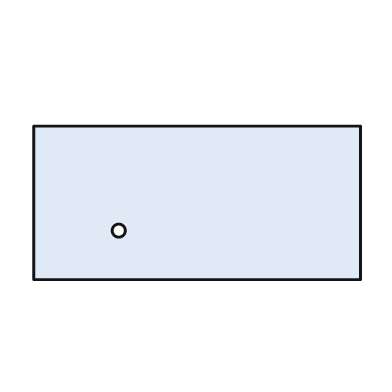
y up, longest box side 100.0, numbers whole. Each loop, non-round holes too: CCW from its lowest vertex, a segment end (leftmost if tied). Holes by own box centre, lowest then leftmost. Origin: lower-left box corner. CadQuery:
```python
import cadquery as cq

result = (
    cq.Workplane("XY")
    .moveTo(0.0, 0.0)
    .lineTo(100.0, 0.0)
    .lineTo(100.0, 47.0)
    .lineTo(0.0, 47.0)
    .close()
    .moveTo(26.0, 15.0)
    .circle(2.0)
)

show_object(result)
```